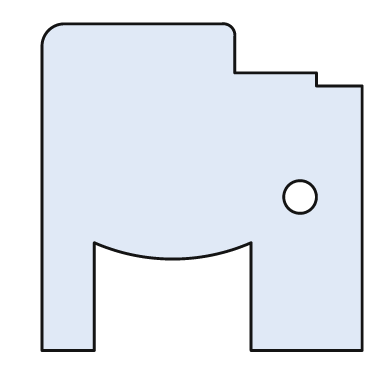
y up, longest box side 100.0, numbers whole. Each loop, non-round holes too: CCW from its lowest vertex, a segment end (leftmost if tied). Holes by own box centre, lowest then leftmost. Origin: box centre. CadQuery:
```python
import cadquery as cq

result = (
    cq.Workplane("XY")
    .moveTo(-49.0, -50.0)
    .lineTo(-33.0, -50.0)
    .lineTo(-33.0, -17.0)
    .threePointArc((-9.0, -22.0), (15.0, -17.0))
    .lineTo(15.0, -50.0)
    .lineTo(49.0, -50.0)
    .lineTo(49.0, 31.0)
    .lineTo(35.0, 31.0)
    .lineTo(35.0, 35.0)
    .lineTo(10.0, 35.0)
    .lineTo(10.0, 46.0)
    .threePointArc((9.0, 49.0), (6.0, 50.0))
    .lineTo(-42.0, 50.0)
    .threePointArc((-47.0, 48.0), (-49.0, 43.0))
    .close()
    .moveTo(30.0, -3.0)
    .circle(5.0)
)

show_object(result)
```